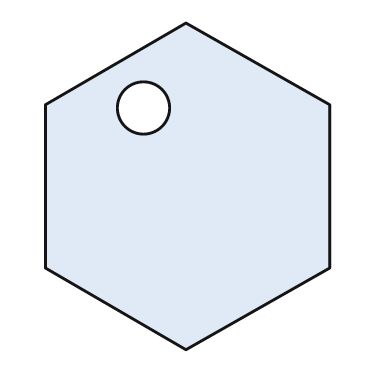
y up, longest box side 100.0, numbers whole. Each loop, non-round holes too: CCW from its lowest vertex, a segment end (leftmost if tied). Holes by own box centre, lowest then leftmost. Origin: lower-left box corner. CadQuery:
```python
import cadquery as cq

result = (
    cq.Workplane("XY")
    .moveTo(43.0, 0.0)
    .lineTo(87.0, 25.0)
    .lineTo(87.0, 75.0)
    .lineTo(43.0, 100.0)
    .lineTo(0.0, 75.0)
    .lineTo(0.0, 25.0)
    .close()
    .moveTo(30.0, 74.0)
    .circle(8.0)
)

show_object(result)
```